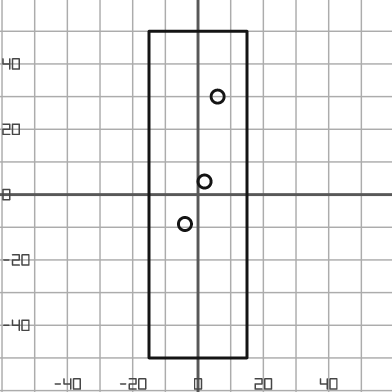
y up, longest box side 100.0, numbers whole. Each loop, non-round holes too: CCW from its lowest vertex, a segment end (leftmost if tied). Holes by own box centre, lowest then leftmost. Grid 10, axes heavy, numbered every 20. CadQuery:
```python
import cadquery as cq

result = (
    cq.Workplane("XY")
    .moveTo(-15.0, -50.0)
    .lineTo(15.0, -50.0)
    .lineTo(15.0, 50.0)
    .lineTo(-15.0, 50.0)
    .close()
    .moveTo(-4.0, -9.0)
    .circle(2.0)
    .moveTo(2.0, 4.0)
    .circle(2.0)
    .moveTo(6.0, 30.0)
    .circle(2.0)
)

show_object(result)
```